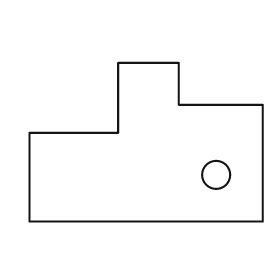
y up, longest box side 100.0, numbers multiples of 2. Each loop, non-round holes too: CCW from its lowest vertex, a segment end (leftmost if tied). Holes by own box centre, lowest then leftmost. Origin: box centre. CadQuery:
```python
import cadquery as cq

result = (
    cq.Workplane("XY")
    .moveTo(-50.0, -34.0)
    .lineTo(50.0, -34.0)
    .lineTo(50.0, 16.0)
    .lineTo(14.0, 16.0)
    .lineTo(14.0, 34.0)
    .lineTo(-12.0, 34.0)
    .lineTo(-12.0, 4.0)
    .lineTo(-50.0, 4.0)
    .close()
    .moveTo(30.0, -14.0)
    .circle(6.0)
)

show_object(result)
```